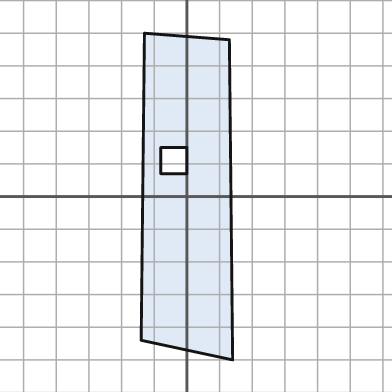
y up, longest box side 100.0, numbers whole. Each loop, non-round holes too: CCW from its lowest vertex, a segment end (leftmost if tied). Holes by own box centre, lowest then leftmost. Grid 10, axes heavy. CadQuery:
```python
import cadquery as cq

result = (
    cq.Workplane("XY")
    .moveTo(14.0, -50.0)
    .lineTo(13.0, 48.0)
    .lineTo(-13.0, 50.0)
    .lineTo(-14.0, -44.0)
    .close()
    .moveTo(-8.0, 7.0)
    .lineTo(0.0, 7.0)
    .lineTo(0.0, 15.0)
    .lineTo(-8.0, 15.0)
    .close()
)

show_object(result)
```